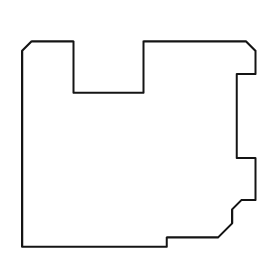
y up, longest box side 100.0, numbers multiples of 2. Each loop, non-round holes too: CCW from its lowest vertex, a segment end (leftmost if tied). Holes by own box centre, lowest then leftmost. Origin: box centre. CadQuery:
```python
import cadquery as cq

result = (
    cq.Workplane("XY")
    .moveTo(-50.0, -44.0)
    .lineTo(12.0, -44.0)
    .lineTo(12.0, -40.0)
    .lineTo(34.0, -40.0)
    .lineTo(40.0, -34.0)
    .lineTo(40.0, -28.0)
    .lineTo(44.0, -24.0)
    .lineTo(50.0, -24.0)
    .lineTo(50.0, -6.0)
    .lineTo(42.0, -6.0)
    .lineTo(42.0, 30.0)
    .lineTo(50.0, 30.0)
    .lineTo(50.0, 40.0)
    .lineTo(46.0, 44.0)
    .lineTo(2.0, 44.0)
    .lineTo(2.0, 22.0)
    .lineTo(-28.0, 22.0)
    .lineTo(-28.0, 44.0)
    .lineTo(-46.0, 44.0)
    .lineTo(-50.0, 40.0)
    .close()
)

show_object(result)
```